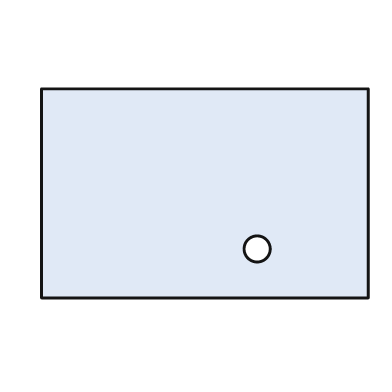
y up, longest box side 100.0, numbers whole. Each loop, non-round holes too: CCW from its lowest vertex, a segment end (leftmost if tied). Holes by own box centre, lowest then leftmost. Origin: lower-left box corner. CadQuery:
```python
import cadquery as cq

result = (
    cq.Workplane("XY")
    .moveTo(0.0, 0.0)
    .lineTo(100.0, 0.0)
    .lineTo(100.0, 64.0)
    .lineTo(0.0, 64.0)
    .close()
    .moveTo(66.0, 15.0)
    .circle(4.0)
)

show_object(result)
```